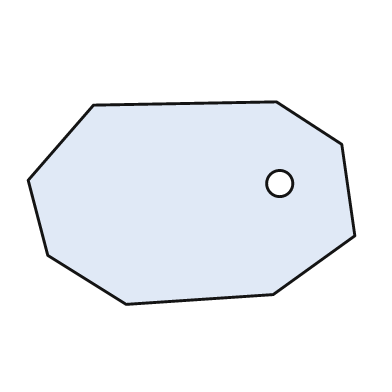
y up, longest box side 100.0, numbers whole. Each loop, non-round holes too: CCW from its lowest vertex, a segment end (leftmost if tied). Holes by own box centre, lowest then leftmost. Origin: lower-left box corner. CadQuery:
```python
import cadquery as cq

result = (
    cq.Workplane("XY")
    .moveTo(30.0, 0.0)
    .lineTo(75.0, 3.0)
    .lineTo(100.0, 21.0)
    .lineTo(96.0, 49.0)
    .lineTo(76.0, 62.0)
    .lineTo(20.0, 61.0)
    .lineTo(0.0, 38.0)
    .lineTo(6.0, 15.0)
    .close()
    .moveTo(77.0, 37.0)
    .circle(4.0)
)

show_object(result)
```